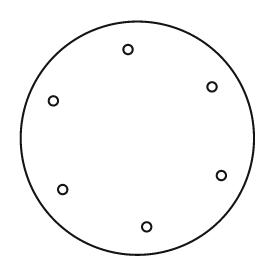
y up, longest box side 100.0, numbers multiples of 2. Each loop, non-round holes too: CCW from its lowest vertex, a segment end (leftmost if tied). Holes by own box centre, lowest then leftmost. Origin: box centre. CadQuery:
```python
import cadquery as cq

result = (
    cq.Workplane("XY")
    .moveTo(0.0, 0.0)
    .circle(50.0)
    .moveTo(4.0, -38.0)
    .circle(2.0)
    .moveTo(-32.0, -22.0)
    .circle(2.0)
    .moveTo(36.0, -16.0)
    .circle(2.0)
    .moveTo(-36.0, 16.0)
    .circle(2.0)
    .moveTo(32.0, 22.0)
    .circle(2.0)
    .moveTo(-4.0, 38.0)
    .circle(2.0)
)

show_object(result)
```